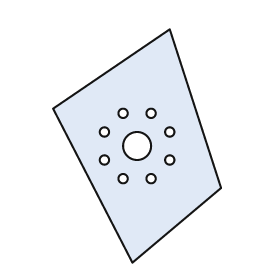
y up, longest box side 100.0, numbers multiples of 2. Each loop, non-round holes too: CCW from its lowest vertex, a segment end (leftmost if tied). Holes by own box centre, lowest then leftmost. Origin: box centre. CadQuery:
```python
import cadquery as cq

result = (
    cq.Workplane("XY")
    .moveTo(-2.0, -50.0)
    .lineTo(36.0, -18.0)
    .lineTo(14.0, 50.0)
    .lineTo(-36.0, 16.0)
    .close()
    .moveTo(-6.0, -14.0)
    .circle(2.0)
    .moveTo(6.0, -14.0)
    .circle(2.0)
    .moveTo(-14.0, -6.0)
    .circle(2.0)
    .moveTo(14.0, -6.0)
    .circle(2.0)
    .moveTo(0.0, 0.0)
    .circle(6.0)
    .moveTo(-14.0, 6.0)
    .circle(2.0)
    .moveTo(14.0, 6.0)
    .circle(2.0)
    .moveTo(-6.0, 14.0)
    .circle(2.0)
    .moveTo(6.0, 14.0)
    .circle(2.0)
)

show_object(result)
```